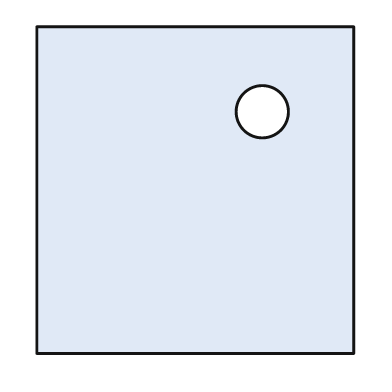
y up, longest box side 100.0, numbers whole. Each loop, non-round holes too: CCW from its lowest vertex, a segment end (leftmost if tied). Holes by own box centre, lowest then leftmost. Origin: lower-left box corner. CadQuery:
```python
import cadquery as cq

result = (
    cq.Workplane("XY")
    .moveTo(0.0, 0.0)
    .lineTo(97.0, 0.0)
    .lineTo(97.0, 100.0)
    .lineTo(0.0, 100.0)
    .close()
    .moveTo(69.0, 74.0)
    .circle(8.0)
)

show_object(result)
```